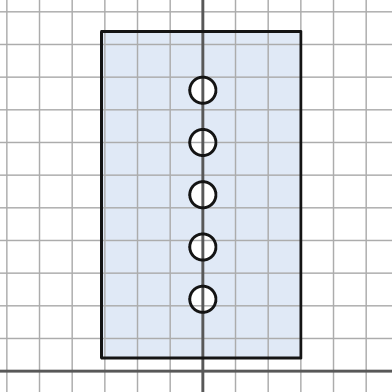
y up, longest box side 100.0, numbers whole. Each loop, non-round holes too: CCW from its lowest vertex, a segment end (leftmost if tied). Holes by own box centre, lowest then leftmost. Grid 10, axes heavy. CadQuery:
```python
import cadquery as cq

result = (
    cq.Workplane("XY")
    .moveTo(-31.0, 4.0)
    .lineTo(30.0, 4.0)
    .lineTo(30.0, 104.0)
    .lineTo(-31.0, 104.0)
    .close()
    .moveTo(0.0, 22.0)
    .circle(4.0)
    .moveTo(0.0, 38.0)
    .circle(4.0)
    .moveTo(0.0, 54.0)
    .circle(4.0)
    .moveTo(0.0, 70.0)
    .circle(4.0)
    .moveTo(0.0, 86.0)
    .circle(4.0)
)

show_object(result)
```